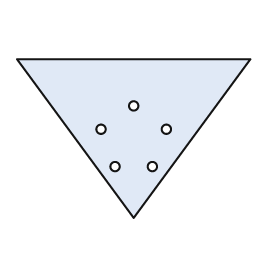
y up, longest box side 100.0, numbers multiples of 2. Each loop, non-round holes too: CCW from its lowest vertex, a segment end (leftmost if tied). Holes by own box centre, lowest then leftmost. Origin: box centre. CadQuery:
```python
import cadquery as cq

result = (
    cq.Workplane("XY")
    .moveTo(0.0, -34.0)
    .lineTo(50.0, 34.0)
    .lineTo(-50.0, 34.0)
    .close()
    .moveTo(-8.0, -12.0)
    .circle(2.0)
    .moveTo(8.0, -12.0)
    .circle(2.0)
    .moveTo(-14.0, 4.0)
    .circle(2.0)
    .moveTo(14.0, 4.0)
    .circle(2.0)
    .moveTo(0.0, 14.0)
    .circle(2.0)
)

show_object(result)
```